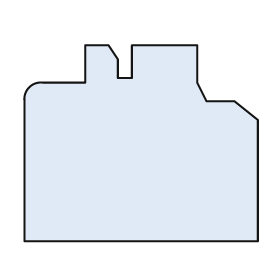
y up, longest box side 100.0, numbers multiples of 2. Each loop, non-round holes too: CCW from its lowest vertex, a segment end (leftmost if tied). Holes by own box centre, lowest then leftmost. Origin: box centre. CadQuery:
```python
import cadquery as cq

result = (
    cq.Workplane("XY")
    .moveTo(-50.0, -42.0)
    .lineTo(50.0, -42.0)
    .lineTo(50.0, 10.0)
    .lineTo(40.0, 18.0)
    .lineTo(28.0, 18.0)
    .lineTo(24.0, 26.0)
    .lineTo(24.0, 42.0)
    .lineTo(-4.0, 42.0)
    .lineTo(-4.0, 28.0)
    .lineTo(-10.0, 28.0)
    .lineTo(-10.0, 36.0)
    .lineTo(-14.0, 42.0)
    .lineTo(-24.0, 42.0)
    .lineTo(-24.0, 26.0)
    .lineTo(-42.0, 26.0)
    .threePointArc((-48.0, 24.0), (-50.0, 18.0))
    .close()
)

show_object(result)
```